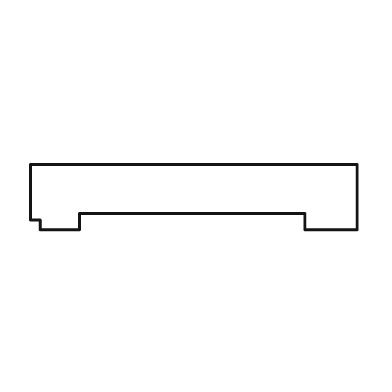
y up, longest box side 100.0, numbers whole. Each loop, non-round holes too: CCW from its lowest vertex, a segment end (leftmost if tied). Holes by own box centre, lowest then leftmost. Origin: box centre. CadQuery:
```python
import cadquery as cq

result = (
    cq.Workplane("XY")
    .moveTo(-47.0, -10.0)
    .lineTo(-35.0, -10.0)
    .lineTo(-35.0, -5.0)
    .lineTo(34.0, -5.0)
    .lineTo(34.0, -10.0)
    .lineTo(50.0, -10.0)
    .lineTo(50.0, 10.0)
    .lineTo(-50.0, 10.0)
    .lineTo(-50.0, -7.0)
    .lineTo(-47.0, -7.0)
    .close()
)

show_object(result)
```